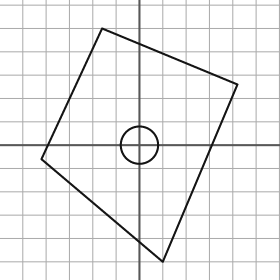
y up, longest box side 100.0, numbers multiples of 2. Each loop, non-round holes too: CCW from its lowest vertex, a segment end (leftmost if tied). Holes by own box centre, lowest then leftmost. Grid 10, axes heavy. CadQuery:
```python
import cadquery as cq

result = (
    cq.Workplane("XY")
    .moveTo(10.0, -50.0)
    .lineTo(42.0, 26.0)
    .lineTo(-16.0, 50.0)
    .lineTo(-42.0, -6.0)
    .close()
    .moveTo(0.0, 0.0)
    .circle(8.0)
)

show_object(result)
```